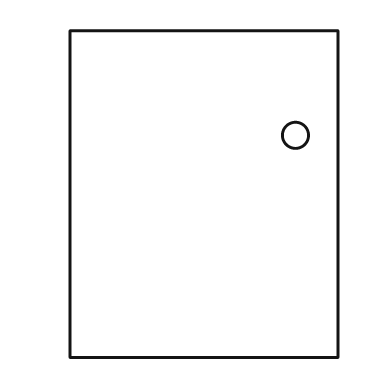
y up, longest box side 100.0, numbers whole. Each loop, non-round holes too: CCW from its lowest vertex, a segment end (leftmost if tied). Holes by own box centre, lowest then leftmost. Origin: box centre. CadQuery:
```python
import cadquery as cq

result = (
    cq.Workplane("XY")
    .moveTo(-41.0, -50.0)
    .lineTo(41.0, -50.0)
    .lineTo(41.0, 50.0)
    .lineTo(-41.0, 50.0)
    .close()
    .moveTo(28.0, 18.0)
    .circle(4.0)
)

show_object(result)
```